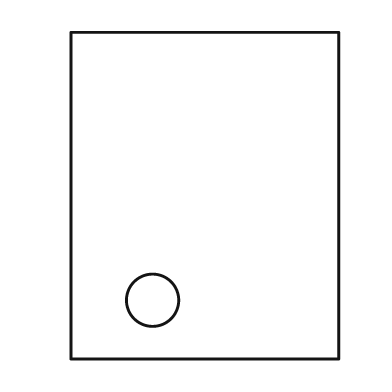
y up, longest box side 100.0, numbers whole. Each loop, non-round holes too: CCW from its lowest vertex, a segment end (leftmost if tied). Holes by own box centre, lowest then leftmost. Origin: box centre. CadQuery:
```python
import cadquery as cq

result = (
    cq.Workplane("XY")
    .moveTo(-41.0, -50.0)
    .lineTo(41.0, -50.0)
    .lineTo(41.0, 50.0)
    .lineTo(-41.0, 50.0)
    .close()
    .moveTo(-16.0, -32.0)
    .circle(8.0)
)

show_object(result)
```